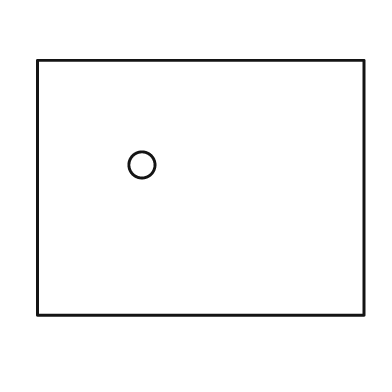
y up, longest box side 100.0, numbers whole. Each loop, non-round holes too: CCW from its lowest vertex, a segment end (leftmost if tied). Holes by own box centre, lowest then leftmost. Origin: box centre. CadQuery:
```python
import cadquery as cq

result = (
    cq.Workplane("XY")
    .moveTo(-50.0, -39.0)
    .lineTo(50.0, -39.0)
    .lineTo(50.0, 39.0)
    .lineTo(-50.0, 39.0)
    .close()
    .moveTo(-18.0, 7.0)
    .circle(4.0)
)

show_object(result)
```